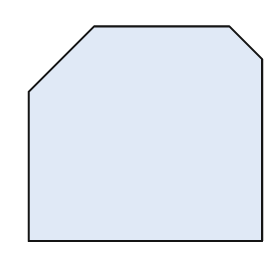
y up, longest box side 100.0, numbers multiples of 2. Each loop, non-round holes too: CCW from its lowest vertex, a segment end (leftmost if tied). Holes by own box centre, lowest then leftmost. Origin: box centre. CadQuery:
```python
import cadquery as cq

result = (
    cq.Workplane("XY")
    .moveTo(-50.0, -46.0)
    .lineTo(50.0, -46.0)
    .lineTo(50.0, 32.0)
    .lineTo(36.0, 46.0)
    .lineTo(-22.0, 46.0)
    .lineTo(-50.0, 18.0)
    .close()
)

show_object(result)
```